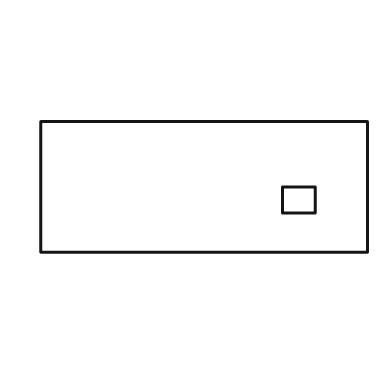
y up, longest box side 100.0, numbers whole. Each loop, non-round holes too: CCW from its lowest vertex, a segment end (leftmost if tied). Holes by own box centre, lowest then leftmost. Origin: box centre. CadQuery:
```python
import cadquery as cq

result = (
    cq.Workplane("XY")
    .moveTo(-50.0, -20.0)
    .lineTo(50.0, -20.0)
    .lineTo(50.0, 20.0)
    .lineTo(-50.0, 20.0)
    .close()
    .moveTo(24.0, -8.0)
    .lineTo(34.0, -8.0)
    .lineTo(34.0, 0.0)
    .lineTo(24.0, 0.0)
    .close()
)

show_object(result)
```